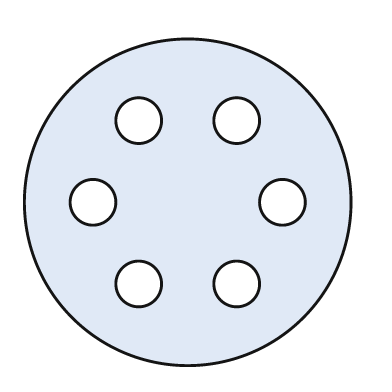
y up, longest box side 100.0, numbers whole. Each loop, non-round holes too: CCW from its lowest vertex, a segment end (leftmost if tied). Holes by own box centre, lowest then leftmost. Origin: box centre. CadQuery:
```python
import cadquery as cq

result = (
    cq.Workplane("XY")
    .moveTo(0.0, 0.0)
    .circle(50.0)
    .moveTo(-15.0, -25.0)
    .circle(7.0)
    .moveTo(15.0, -25.0)
    .circle(7.0)
    .moveTo(-29.0, 0.0)
    .circle(7.0)
    .moveTo(29.0, 0.0)
    .circle(7.0)
    .moveTo(-15.0, 25.0)
    .circle(7.0)
    .moveTo(15.0, 25.0)
    .circle(7.0)
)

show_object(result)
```